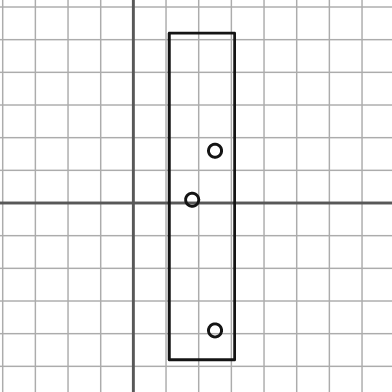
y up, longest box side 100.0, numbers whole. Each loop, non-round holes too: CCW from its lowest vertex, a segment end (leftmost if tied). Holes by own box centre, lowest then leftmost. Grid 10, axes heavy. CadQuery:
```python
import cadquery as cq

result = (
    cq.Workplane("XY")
    .moveTo(11.0, -48.0)
    .lineTo(31.0, -48.0)
    .lineTo(31.0, 52.0)
    .lineTo(11.0, 52.0)
    .close()
    .moveTo(25.0, -39.0)
    .circle(2.0)
    .moveTo(18.0, 1.0)
    .circle(2.0)
    .moveTo(25.0, 16.0)
    .circle(2.0)
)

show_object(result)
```